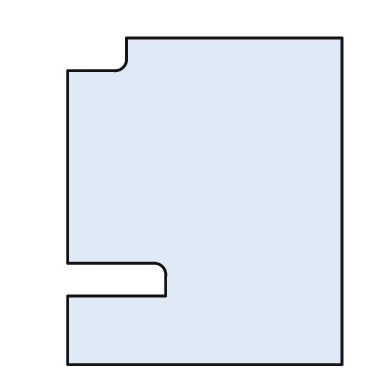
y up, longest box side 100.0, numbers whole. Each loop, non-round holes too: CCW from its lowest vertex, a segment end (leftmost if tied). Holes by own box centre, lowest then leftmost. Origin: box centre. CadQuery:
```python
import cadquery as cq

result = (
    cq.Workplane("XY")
    .moveTo(-42.0, -50.0)
    .lineTo(42.0, -50.0)
    .lineTo(42.0, 50.0)
    .lineTo(-24.0, 50.0)
    .lineTo(-24.0, 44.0)
    .threePointArc((-25.0, 41.0), (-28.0, 40.0))
    .lineTo(-42.0, 40.0)
    .lineTo(-42.0, -19.0)
    .lineTo(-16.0, -19.0)
    .threePointArc((-13.0, -20.0), (-12.0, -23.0))
    .lineTo(-12.0, -29.0)
    .lineTo(-42.0, -29.0)
    .close()
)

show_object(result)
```